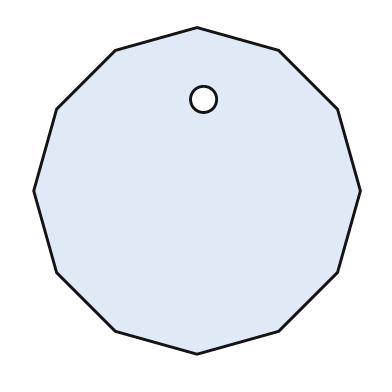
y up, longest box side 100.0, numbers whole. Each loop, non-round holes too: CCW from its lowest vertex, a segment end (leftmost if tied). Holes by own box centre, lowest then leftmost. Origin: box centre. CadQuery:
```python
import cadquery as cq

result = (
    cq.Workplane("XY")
    .moveTo(0.0, -50.0)
    .lineTo(25.0, -43.0)
    .lineTo(43.0, -25.0)
    .lineTo(50.0, 0.0)
    .lineTo(43.0, 25.0)
    .lineTo(25.0, 43.0)
    .lineTo(0.0, 50.0)
    .lineTo(-25.0, 43.0)
    .lineTo(-43.0, 25.0)
    .lineTo(-50.0, 0.0)
    .lineTo(-43.0, -25.0)
    .lineTo(-25.0, -43.0)
    .close()
    .moveTo(2.0, 28.0)
    .circle(4.0)
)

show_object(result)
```